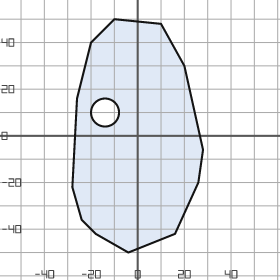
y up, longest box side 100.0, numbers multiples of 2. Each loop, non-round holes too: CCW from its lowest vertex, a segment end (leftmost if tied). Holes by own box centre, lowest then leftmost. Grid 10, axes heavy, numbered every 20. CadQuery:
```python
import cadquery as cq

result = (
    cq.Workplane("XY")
    .moveTo(-4.0, -50.0)
    .lineTo(16.0, -42.0)
    .lineTo(26.0, -20.0)
    .lineTo(28.0, -6.0)
    .lineTo(20.0, 30.0)
    .lineTo(10.0, 48.0)
    .lineTo(-10.0, 50.0)
    .lineTo(-20.0, 40.0)
    .lineTo(-26.0, 16.0)
    .lineTo(-28.0, -22.0)
    .lineTo(-24.0, -36.0)
    .lineTo(-18.0, -42.0)
    .close()
    .moveTo(-14.0, 10.0)
    .circle(6.0)
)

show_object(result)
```